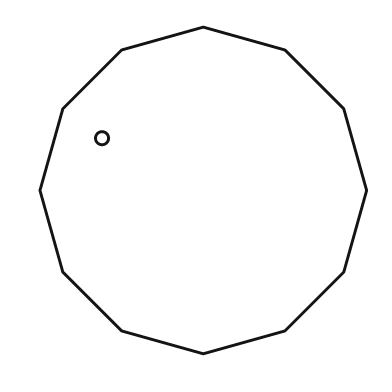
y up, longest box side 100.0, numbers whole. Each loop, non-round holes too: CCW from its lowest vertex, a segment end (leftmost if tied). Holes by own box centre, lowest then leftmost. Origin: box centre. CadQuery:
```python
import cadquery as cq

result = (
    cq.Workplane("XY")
    .moveTo(0.0, -50.0)
    .lineTo(25.0, -43.0)
    .lineTo(43.0, -25.0)
    .lineTo(50.0, 0.0)
    .lineTo(43.0, 25.0)
    .lineTo(25.0, 43.0)
    .lineTo(0.0, 50.0)
    .lineTo(-25.0, 43.0)
    .lineTo(-43.0, 25.0)
    .lineTo(-50.0, 0.0)
    .lineTo(-43.0, -25.0)
    .lineTo(-25.0, -43.0)
    .close()
    .moveTo(-31.0, 16.0)
    .circle(2.0)
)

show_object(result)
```